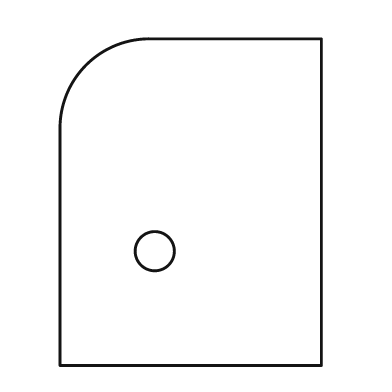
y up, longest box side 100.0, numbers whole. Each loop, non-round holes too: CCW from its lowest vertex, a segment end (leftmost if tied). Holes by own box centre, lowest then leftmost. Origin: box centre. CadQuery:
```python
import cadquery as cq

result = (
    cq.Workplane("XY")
    .moveTo(-40.0, -50.0)
    .lineTo(40.0, -50.0)
    .lineTo(40.0, 50.0)
    .lineTo(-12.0, 50.0)
    .threePointArc((-32.0, 42.0), (-40.0, 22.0))
    .close()
    .moveTo(-11.0, -15.0)
    .circle(6.0)
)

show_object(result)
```